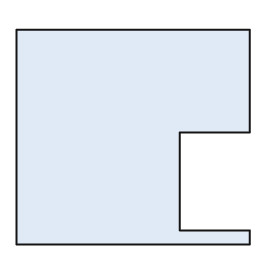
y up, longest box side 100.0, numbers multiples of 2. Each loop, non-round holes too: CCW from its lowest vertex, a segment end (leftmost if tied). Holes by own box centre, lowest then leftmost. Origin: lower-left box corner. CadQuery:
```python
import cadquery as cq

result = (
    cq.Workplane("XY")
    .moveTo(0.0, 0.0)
    .lineTo(100.0, 0.0)
    .lineTo(100.0, 6.0)
    .lineTo(70.0, 6.0)
    .lineTo(70.0, 48.0)
    .lineTo(100.0, 48.0)
    .lineTo(100.0, 92.0)
    .lineTo(0.0, 92.0)
    .close()
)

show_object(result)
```